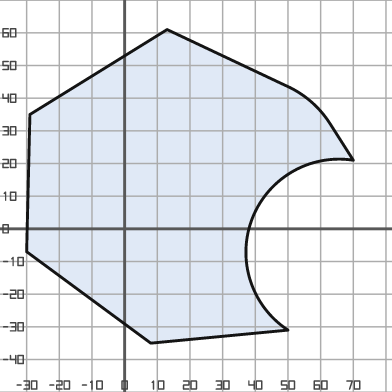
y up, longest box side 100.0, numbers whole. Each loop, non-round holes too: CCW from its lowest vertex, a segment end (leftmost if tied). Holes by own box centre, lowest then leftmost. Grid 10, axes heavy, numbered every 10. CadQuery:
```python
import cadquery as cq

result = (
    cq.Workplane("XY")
    .moveTo(8.0, -35.0)
    .lineTo(50.0, -31.0)
    .threePointArc((39.0, 3.0), (70.0, 21.0))
    .lineTo(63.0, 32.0)
    .threePointArc((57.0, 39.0), (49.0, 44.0))
    .lineTo(13.0, 61.0)
    .lineTo(-29.0, 35.0)
    .lineTo(-30.0, -7.0)
    .close()
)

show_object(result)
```